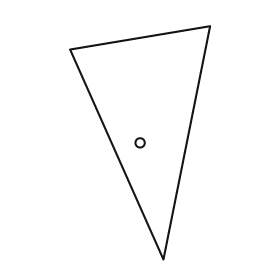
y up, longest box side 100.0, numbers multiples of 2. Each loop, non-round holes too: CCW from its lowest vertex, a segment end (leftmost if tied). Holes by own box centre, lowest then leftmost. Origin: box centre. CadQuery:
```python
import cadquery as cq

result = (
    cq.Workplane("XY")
    .moveTo(10.0, -50.0)
    .lineTo(30.0, 50.0)
    .lineTo(-30.0, 40.0)
    .close()
    .moveTo(0.0, 0.0)
    .circle(2.0)
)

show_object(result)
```